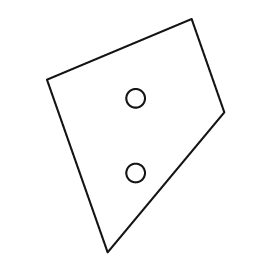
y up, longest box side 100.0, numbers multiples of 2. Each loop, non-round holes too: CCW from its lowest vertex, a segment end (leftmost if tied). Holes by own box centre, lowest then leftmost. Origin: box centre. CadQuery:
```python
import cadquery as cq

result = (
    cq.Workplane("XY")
    .moveTo(-12.0, -50.0)
    .lineTo(38.0, 10.0)
    .lineTo(24.0, 50.0)
    .lineTo(-38.0, 24.0)
    .close()
    .moveTo(0.0, -16.0)
    .circle(4.0)
    .moveTo(0.0, 16.0)
    .circle(4.0)
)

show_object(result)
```